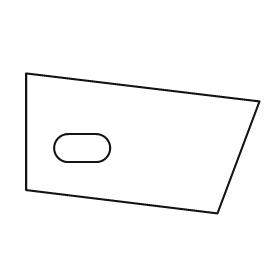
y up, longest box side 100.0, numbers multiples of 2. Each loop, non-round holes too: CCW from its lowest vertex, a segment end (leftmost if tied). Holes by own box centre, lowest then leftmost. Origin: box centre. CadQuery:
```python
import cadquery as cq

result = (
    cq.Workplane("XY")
    .moveTo(32.0, -30.0)
    .lineTo(50.0, 18.0)
    .lineTo(-50.0, 30.0)
    .lineTo(-50.0, -20.0)
    .close()
    .moveTo(-32.0, -8.0)
    .lineTo(-20.0, -8.0)
    .threePointArc((-14.0, -2.0), (-20.0, 4.0))
    .lineTo(-32.0, 4.0)
    .threePointArc((-38.0, -2.0), (-32.0, -8.0))
    .close()
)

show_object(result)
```